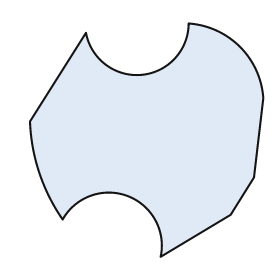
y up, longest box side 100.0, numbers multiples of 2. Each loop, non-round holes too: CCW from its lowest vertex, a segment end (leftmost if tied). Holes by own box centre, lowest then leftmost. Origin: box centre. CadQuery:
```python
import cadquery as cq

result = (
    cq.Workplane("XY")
    .moveTo(6.0, -50.0)
    .lineTo(36.0, -32.0)
    .lineTo(46.0, -16.0)
    .lineTo(50.0, 18.0)
    .threePointArc((40.0, 40.0), (18.0, 50.0))
    .threePointArc((-2.0, 28.0), (-26.0, 46.0))
    .lineTo(-50.0, 8.0)
    .threePointArc((-46.0, -14.0), (-36.0, -34.0))
    .threePointArc((-8.0, -24.0), (6.0, -50.0))
    .close()
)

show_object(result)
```